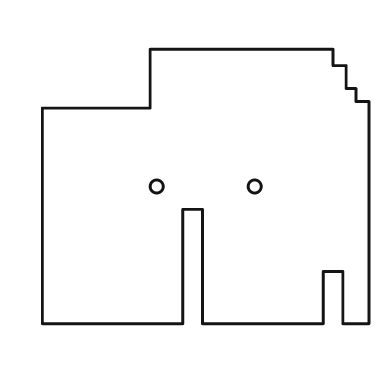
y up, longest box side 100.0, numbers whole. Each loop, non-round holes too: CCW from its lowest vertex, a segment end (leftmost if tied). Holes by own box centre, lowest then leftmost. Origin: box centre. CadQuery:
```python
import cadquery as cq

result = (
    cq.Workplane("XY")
    .moveTo(-50.0, -42.0)
    .lineTo(-7.0, -42.0)
    .lineTo(-7.0, -7.0)
    .lineTo(-1.0, -7.0)
    .lineTo(-1.0, -42.0)
    .lineTo(36.0, -42.0)
    .lineTo(36.0, -26.0)
    .lineTo(42.0, -26.0)
    .lineTo(42.0, -42.0)
    .lineTo(50.0, -42.0)
    .lineTo(50.0, 26.0)
    .lineTo(46.0, 26.0)
    .lineTo(46.0, 30.0)
    .lineTo(43.0, 30.0)
    .lineTo(43.0, 37.0)
    .lineTo(39.0, 37.0)
    .lineTo(39.0, 42.0)
    .lineTo(-17.0, 42.0)
    .lineTo(-17.0, 24.0)
    .lineTo(-50.0, 24.0)
    .close()
    .moveTo(-15.0, 0.0)
    .circle(2.0)
    .moveTo(15.0, 0.0)
    .circle(2.0)
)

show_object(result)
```